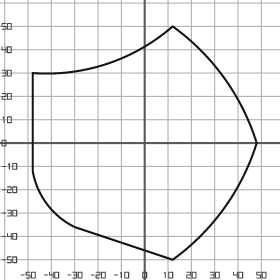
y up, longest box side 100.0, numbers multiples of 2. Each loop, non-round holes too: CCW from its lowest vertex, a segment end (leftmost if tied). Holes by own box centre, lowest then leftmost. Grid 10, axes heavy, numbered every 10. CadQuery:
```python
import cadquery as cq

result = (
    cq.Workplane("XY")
    .moveTo(12.0, -50.0)
    .threePointArc((34.0, -28.0), (48.0, 0.0))
    .threePointArc((34.0, 28.0), (12.0, 50.0))
    .threePointArc((-16.0, 34.0), (-48.0, 30.0))
    .lineTo(-48.0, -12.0)
    .threePointArc((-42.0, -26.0), (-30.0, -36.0))
    .close()
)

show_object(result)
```